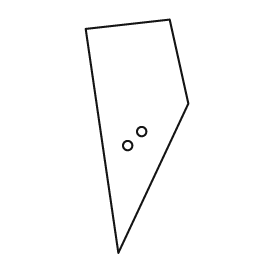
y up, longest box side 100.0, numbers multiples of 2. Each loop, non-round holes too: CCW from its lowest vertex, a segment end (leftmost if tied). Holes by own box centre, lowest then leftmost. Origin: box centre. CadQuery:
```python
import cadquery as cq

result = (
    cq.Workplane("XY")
    .moveTo(-8.0, -50.0)
    .lineTo(22.0, 14.0)
    .lineTo(14.0, 50.0)
    .lineTo(-22.0, 46.0)
    .close()
    .moveTo(-4.0, -4.0)
    .circle(2.0)
    .moveTo(2.0, 2.0)
    .circle(2.0)
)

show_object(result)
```